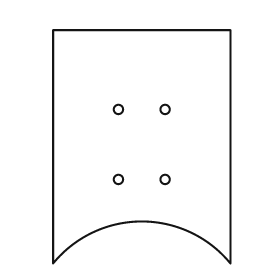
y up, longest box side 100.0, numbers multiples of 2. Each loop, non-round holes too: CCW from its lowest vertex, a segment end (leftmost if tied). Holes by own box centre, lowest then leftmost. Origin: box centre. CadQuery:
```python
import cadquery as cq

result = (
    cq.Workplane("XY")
    .moveTo(-38.0, -50.0)
    .threePointArc((0.0, -32.0), (38.0, -50.0))
    .lineTo(38.0, 50.0)
    .lineTo(-38.0, 50.0)
    .close()
    .moveTo(-10.0, -14.0)
    .circle(2.0)
    .moveTo(10.0, -14.0)
    .circle(2.0)
    .moveTo(-10.0, 16.0)
    .circle(2.0)
    .moveTo(10.0, 16.0)
    .circle(2.0)
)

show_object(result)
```